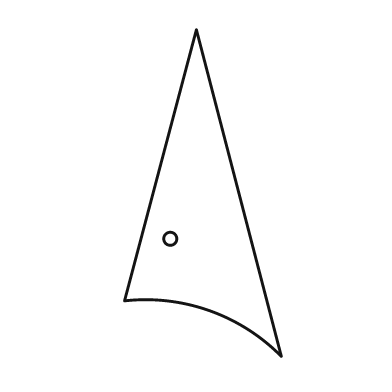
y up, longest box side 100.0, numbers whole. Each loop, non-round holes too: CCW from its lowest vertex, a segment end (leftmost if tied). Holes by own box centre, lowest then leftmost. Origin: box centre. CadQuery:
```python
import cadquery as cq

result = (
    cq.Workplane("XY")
    .moveTo(24.0, -50.0)
    .lineTo(-2.0, 50.0)
    .lineTo(-24.0, -33.0)
    .threePointArc((2.0, -36.0), (24.0, -50.0))
    .close()
    .moveTo(-10.0, -14.0)
    .circle(2.0)
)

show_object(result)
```